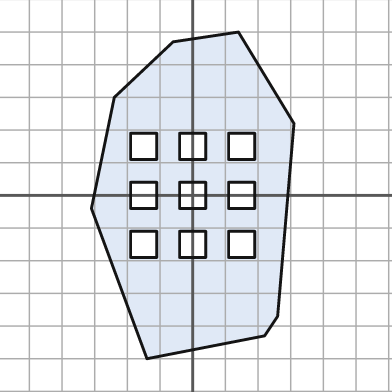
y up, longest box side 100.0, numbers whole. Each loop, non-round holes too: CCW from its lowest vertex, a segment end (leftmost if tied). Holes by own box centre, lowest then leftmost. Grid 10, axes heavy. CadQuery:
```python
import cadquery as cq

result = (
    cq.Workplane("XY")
    .moveTo(-14.0, -50.0)
    .lineTo(22.0, -43.0)
    .lineTo(26.0, -37.0)
    .lineTo(31.0, 22.0)
    .lineTo(14.0, 50.0)
    .lineTo(-6.0, 47.0)
    .lineTo(-24.0, 30.0)
    .lineTo(-31.0, -4.0)
    .close()
    .moveTo(-19.0, -19.0)
    .lineTo(-11.0, -19.0)
    .lineTo(-11.0, -11.0)
    .lineTo(-19.0, -11.0)
    .close()
    .moveTo(-4.0, -19.0)
    .lineTo(4.0, -19.0)
    .lineTo(4.0, -11.0)
    .lineTo(-4.0, -11.0)
    .close()
    .moveTo(11.0, -19.0)
    .lineTo(19.0, -19.0)
    .lineTo(19.0, -11.0)
    .lineTo(11.0, -11.0)
    .close()
    .moveTo(-19.0, -4.0)
    .lineTo(-11.0, -4.0)
    .lineTo(-11.0, 4.0)
    .lineTo(-19.0, 4.0)
    .close()
    .moveTo(-4.0, -4.0)
    .lineTo(4.0, -4.0)
    .lineTo(4.0, 4.0)
    .lineTo(-4.0, 4.0)
    .close()
    .moveTo(11.0, -4.0)
    .lineTo(19.0, -4.0)
    .lineTo(19.0, 4.0)
    .lineTo(11.0, 4.0)
    .close()
    .moveTo(-19.0, 11.0)
    .lineTo(-11.0, 11.0)
    .lineTo(-11.0, 19.0)
    .lineTo(-19.0, 19.0)
    .close()
    .moveTo(-4.0, 11.0)
    .lineTo(4.0, 11.0)
    .lineTo(4.0, 19.0)
    .lineTo(-4.0, 19.0)
    .close()
    .moveTo(11.0, 11.0)
    .lineTo(19.0, 11.0)
    .lineTo(19.0, 19.0)
    .lineTo(11.0, 19.0)
    .close()
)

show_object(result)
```